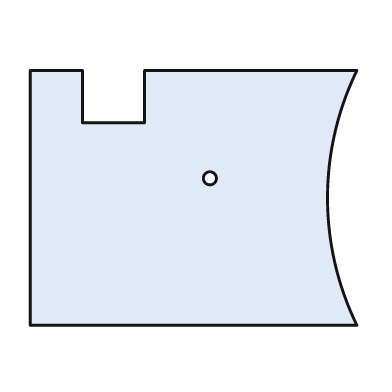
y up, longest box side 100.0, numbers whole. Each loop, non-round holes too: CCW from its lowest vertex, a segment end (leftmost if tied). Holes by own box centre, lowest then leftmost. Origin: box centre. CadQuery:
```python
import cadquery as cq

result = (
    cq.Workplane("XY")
    .moveTo(-50.0, -39.0)
    .lineTo(50.0, -39.0)
    .threePointArc((41.0, 0.0), (50.0, 39.0))
    .lineTo(-15.0, 39.0)
    .lineTo(-15.0, 23.0)
    .lineTo(-34.0, 23.0)
    .lineTo(-34.0, 39.0)
    .lineTo(-50.0, 39.0)
    .close()
    .moveTo(5.0, 6.0)
    .circle(2.0)
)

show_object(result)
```